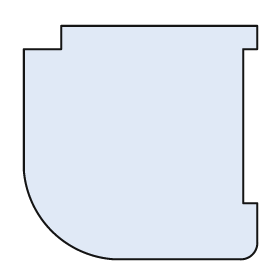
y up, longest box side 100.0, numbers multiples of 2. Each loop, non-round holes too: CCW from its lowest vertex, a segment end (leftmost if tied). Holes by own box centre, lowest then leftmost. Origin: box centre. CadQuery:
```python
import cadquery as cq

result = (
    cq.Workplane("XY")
    .moveTo(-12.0, -50.0)
    .lineTo(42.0, -50.0)
    .threePointArc((48.0, -48.0), (50.0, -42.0))
    .lineTo(50.0, -26.0)
    .lineTo(44.0, -26.0)
    .lineTo(44.0, 40.0)
    .lineTo(50.0, 40.0)
    .lineTo(50.0, 50.0)
    .lineTo(-34.0, 50.0)
    .lineTo(-34.0, 40.0)
    .lineTo(-50.0, 40.0)
    .lineTo(-50.0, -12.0)
    .threePointArc((-38.0, -38.0), (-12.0, -50.0))
    .close()
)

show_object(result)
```